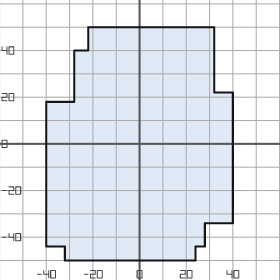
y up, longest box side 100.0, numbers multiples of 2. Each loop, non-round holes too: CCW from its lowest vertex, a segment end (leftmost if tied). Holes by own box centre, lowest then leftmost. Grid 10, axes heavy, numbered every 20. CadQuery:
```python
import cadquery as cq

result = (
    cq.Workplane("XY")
    .moveTo(-32.0, -50.0)
    .lineTo(24.0, -50.0)
    .lineTo(24.0, -44.0)
    .lineTo(28.0, -44.0)
    .lineTo(28.0, -34.0)
    .lineTo(40.0, -34.0)
    .lineTo(40.0, 22.0)
    .lineTo(32.0, 22.0)
    .lineTo(32.0, 50.0)
    .lineTo(-22.0, 50.0)
    .lineTo(-22.0, 40.0)
    .lineTo(-28.0, 40.0)
    .lineTo(-28.0, 18.0)
    .lineTo(-40.0, 18.0)
    .lineTo(-40.0, -44.0)
    .lineTo(-32.0, -44.0)
    .close()
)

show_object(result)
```